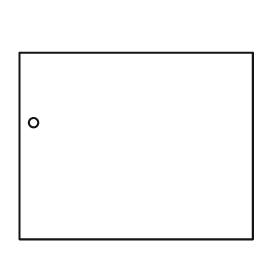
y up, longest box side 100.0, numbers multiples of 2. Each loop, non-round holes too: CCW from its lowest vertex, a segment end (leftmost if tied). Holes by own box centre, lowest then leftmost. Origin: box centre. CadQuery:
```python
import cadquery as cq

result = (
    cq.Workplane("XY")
    .moveTo(-50.0, -40.0)
    .lineTo(50.0, -40.0)
    .lineTo(50.0, 40.0)
    .lineTo(-50.0, 40.0)
    .close()
    .moveTo(-44.0, 10.0)
    .circle(2.0)
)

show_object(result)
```